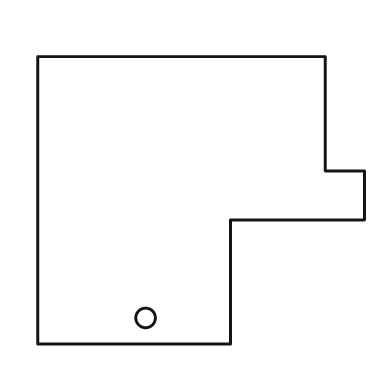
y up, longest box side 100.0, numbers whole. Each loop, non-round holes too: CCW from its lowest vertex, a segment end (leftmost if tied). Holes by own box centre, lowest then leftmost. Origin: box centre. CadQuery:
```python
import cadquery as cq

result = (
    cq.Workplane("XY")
    .moveTo(-50.0, -44.0)
    .lineTo(9.0, -44.0)
    .lineTo(9.0, -6.0)
    .lineTo(50.0, -6.0)
    .lineTo(50.0, 9.0)
    .lineTo(38.0, 9.0)
    .lineTo(38.0, 44.0)
    .lineTo(-50.0, 44.0)
    .close()
    .moveTo(-17.0, -36.0)
    .circle(3.0)
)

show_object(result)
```